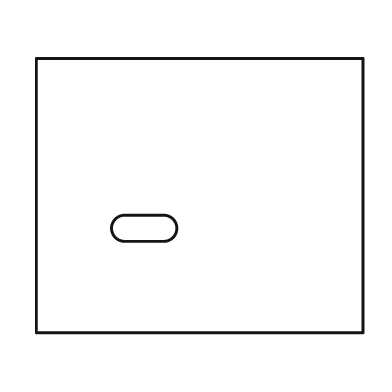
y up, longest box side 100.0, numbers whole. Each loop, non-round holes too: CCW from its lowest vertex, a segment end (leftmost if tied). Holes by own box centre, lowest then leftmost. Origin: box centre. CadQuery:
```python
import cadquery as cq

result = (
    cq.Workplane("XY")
    .moveTo(-50.0, -42.0)
    .lineTo(50.0, -42.0)
    .lineTo(50.0, 42.0)
    .lineTo(-50.0, 42.0)
    .close()
    .moveTo(-23.0, -14.0)
    .lineTo(-11.0, -14.0)
    .threePointArc((-7.0, -10.0), (-11.0, -6.0))
    .lineTo(-23.0, -6.0)
    .threePointArc((-27.0, -10.0), (-23.0, -14.0))
    .close()
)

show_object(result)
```